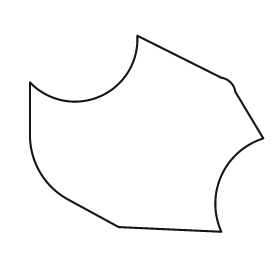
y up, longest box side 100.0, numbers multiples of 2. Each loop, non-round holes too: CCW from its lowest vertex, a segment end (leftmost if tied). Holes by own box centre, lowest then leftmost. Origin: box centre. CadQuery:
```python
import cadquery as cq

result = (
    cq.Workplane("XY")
    .moveTo(32.0, -42.0)
    .threePointArc((32.0, -18.0), (50.0, -2.0))
    .lineTo(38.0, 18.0)
    .threePointArc((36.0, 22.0), (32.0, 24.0))
    .lineTo(-4.0, 42.0)
    .threePointArc((-20.0, 16.0), (-50.0, 22.0))
    .lineTo(-50.0, 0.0)
    .threePointArc((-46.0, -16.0), (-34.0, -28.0))
    .lineTo(-12.0, -40.0)
    .close()
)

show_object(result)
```